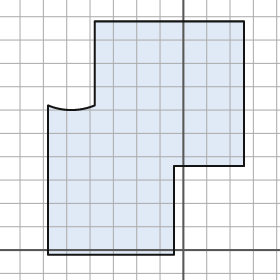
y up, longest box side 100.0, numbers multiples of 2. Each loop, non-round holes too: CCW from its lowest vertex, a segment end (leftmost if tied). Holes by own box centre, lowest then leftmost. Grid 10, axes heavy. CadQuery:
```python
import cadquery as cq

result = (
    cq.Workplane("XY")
    .moveTo(-58.0, -2.0)
    .lineTo(-4.0, -2.0)
    .lineTo(-4.0, 36.0)
    .lineTo(26.0, 36.0)
    .lineTo(26.0, 98.0)
    .lineTo(-38.0, 98.0)
    .lineTo(-38.0, 62.0)
    .threePointArc((-48.0, 60.0), (-58.0, 62.0))
    .close()
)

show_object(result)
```